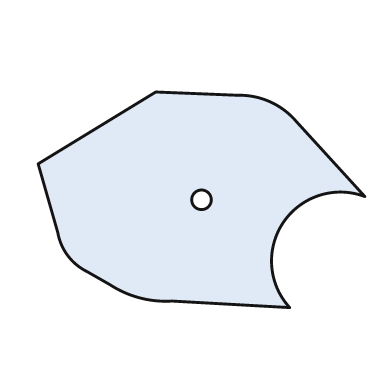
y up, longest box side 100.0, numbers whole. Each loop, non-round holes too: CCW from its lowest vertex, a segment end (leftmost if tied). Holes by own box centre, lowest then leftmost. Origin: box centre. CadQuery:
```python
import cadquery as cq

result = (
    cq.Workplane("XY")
    .moveTo(27.0, -33.0)
    .threePointArc((25.0, -7.0), (50.0, 1.0))
    .lineTo(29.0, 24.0)
    .threePointArc((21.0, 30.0), (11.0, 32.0))
    .lineTo(-14.0, 33.0)
    .lineTo(-50.0, 11.0)
    .lineTo(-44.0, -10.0)
    .threePointArc((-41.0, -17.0), (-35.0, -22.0))
    .lineTo(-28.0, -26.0)
    .threePointArc((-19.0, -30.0), (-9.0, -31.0))
    .close()
    .moveTo(0.0, 0.0)
    .circle(3.0)
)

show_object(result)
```